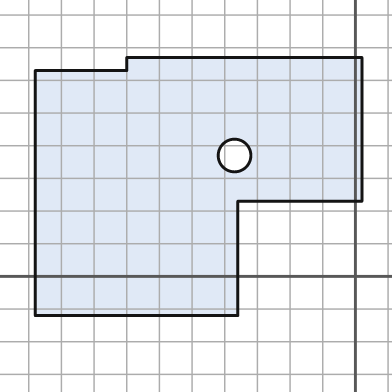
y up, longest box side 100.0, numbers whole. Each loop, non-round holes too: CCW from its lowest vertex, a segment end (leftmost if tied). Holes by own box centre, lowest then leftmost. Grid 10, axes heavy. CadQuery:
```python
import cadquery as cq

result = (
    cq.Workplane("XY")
    .moveTo(-98.0, -12.0)
    .lineTo(-36.0, -12.0)
    .lineTo(-36.0, 23.0)
    .lineTo(2.0, 23.0)
    .lineTo(2.0, 67.0)
    .lineTo(-70.0, 67.0)
    .lineTo(-70.0, 63.0)
    .lineTo(-98.0, 63.0)
    .close()
    .moveTo(-37.0, 37.0)
    .circle(5.0)
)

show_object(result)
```